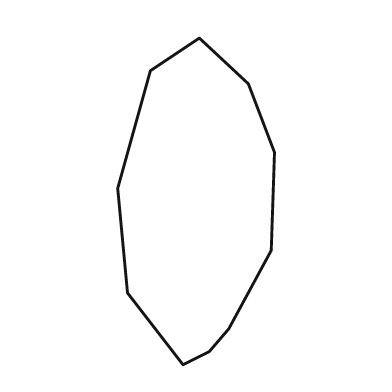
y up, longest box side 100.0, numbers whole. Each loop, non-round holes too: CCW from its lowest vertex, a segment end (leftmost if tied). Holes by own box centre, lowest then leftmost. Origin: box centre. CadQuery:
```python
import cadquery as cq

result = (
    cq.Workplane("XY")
    .moveTo(-4.0, -50.0)
    .lineTo(4.0, -46.0)
    .lineTo(10.0, -39.0)
    .lineTo(23.0, -15.0)
    .lineTo(24.0, 15.0)
    .lineTo(16.0, 36.0)
    .lineTo(1.0, 50.0)
    .lineTo(-14.0, 40.0)
    .lineTo(-24.0, 4.0)
    .lineTo(-21.0, -28.0)
    .close()
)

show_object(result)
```